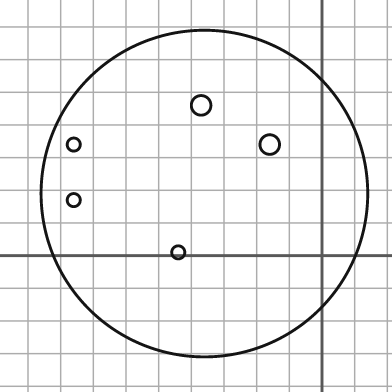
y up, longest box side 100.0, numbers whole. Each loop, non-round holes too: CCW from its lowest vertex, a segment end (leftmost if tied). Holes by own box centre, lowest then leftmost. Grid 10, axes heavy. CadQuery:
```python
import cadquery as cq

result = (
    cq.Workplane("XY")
    .moveTo(-36.0, 19.0)
    .circle(50.0)
    .moveTo(-44.0, 1.0)
    .circle(2.0)
    .moveTo(-76.0, 17.0)
    .circle(2.0)
    .moveTo(-76.0, 34.0)
    .circle(2.0)
    .moveTo(-16.0, 34.0)
    .circle(3.0)
    .moveTo(-37.0, 46.0)
    .circle(3.0)
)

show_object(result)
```